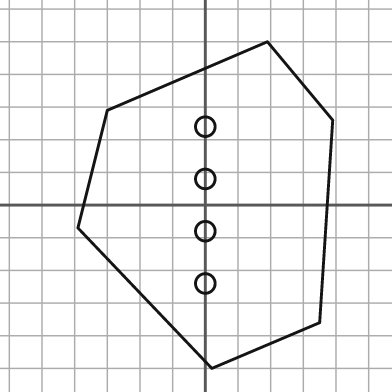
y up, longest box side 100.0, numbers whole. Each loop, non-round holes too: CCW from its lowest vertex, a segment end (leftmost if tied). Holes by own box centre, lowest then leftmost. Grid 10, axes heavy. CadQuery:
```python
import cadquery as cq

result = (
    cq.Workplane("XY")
    .moveTo(2.0, -50.0)
    .lineTo(35.0, -36.0)
    .lineTo(39.0, 26.0)
    .lineTo(19.0, 50.0)
    .lineTo(-30.0, 29.0)
    .lineTo(-39.0, -7.0)
    .close()
    .moveTo(0.0, -24.0)
    .circle(3.0)
    .moveTo(0.0, -8.0)
    .circle(3.0)
    .moveTo(0.0, 8.0)
    .circle(3.0)
    .moveTo(0.0, 24.0)
    .circle(3.0)
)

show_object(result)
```